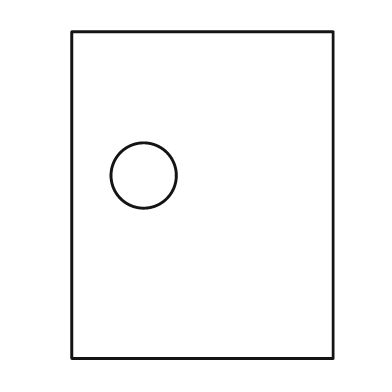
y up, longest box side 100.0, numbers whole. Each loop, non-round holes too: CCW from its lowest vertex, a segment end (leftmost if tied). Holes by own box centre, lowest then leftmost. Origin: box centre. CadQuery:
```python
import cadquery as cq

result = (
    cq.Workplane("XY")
    .moveTo(-40.0, -50.0)
    .lineTo(40.0, -50.0)
    .lineTo(40.0, 50.0)
    .lineTo(-40.0, 50.0)
    .close()
    .moveTo(-18.0, 6.0)
    .circle(10.0)
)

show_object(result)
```